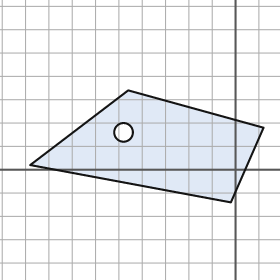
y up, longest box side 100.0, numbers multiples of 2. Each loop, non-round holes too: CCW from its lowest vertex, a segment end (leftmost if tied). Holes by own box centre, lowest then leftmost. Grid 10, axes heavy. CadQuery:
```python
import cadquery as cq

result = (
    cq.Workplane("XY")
    .moveTo(-2.0, -14.0)
    .lineTo(12.0, 18.0)
    .lineTo(-46.0, 34.0)
    .lineTo(-88.0, 2.0)
    .close()
    .moveTo(-48.0, 16.0)
    .circle(4.0)
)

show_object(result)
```